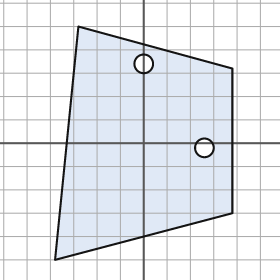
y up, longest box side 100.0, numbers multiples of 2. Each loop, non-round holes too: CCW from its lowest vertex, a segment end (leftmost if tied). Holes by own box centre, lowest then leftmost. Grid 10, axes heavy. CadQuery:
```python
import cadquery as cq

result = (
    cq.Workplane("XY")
    .moveTo(-38.0, -50.0)
    .lineTo(38.0, -30.0)
    .lineTo(38.0, 32.0)
    .lineTo(-28.0, 50.0)
    .close()
    .moveTo(26.0, -2.0)
    .circle(4.0)
    .moveTo(0.0, 34.0)
    .circle(4.0)
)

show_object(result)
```